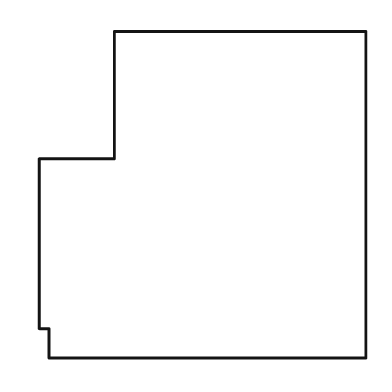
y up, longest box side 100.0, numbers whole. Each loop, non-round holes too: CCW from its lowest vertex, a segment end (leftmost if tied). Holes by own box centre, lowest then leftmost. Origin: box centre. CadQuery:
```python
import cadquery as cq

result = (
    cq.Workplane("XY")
    .moveTo(-47.0, -50.0)
    .lineTo(50.0, -50.0)
    .lineTo(50.0, 50.0)
    .lineTo(-27.0, 50.0)
    .lineTo(-27.0, 11.0)
    .lineTo(-50.0, 11.0)
    .lineTo(-50.0, -41.0)
    .lineTo(-47.0, -41.0)
    .close()
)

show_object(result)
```